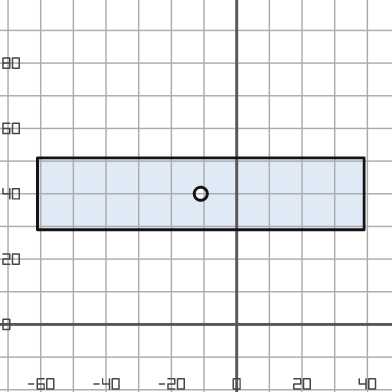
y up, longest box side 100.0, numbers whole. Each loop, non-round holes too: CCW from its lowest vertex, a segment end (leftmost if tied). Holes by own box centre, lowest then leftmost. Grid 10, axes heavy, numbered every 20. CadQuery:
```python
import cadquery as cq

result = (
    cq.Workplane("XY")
    .moveTo(-61.0, 29.0)
    .lineTo(39.0, 29.0)
    .lineTo(39.0, 51.0)
    .lineTo(-61.0, 51.0)
    .close()
    .moveTo(-11.0, 40.0)
    .circle(2.0)
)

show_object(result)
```